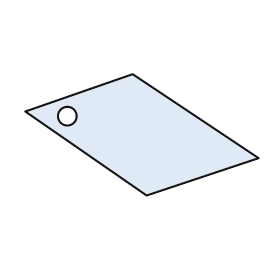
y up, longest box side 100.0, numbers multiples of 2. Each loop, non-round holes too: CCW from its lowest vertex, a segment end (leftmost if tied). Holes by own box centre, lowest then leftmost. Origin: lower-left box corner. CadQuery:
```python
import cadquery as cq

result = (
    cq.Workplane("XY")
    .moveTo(52.0, 0.0)
    .lineTo(100.0, 16.0)
    .lineTo(46.0, 52.0)
    .lineTo(0.0, 36.0)
    .close()
    .moveTo(18.0, 34.0)
    .circle(4.0)
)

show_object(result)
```